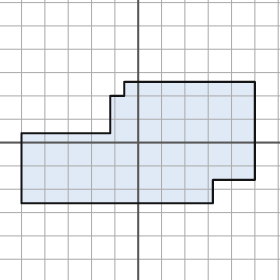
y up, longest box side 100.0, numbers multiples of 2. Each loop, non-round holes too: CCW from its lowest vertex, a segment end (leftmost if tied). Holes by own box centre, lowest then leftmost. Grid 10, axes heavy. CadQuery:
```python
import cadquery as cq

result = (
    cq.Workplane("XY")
    .moveTo(-50.0, -26.0)
    .lineTo(32.0, -26.0)
    .lineTo(32.0, -16.0)
    .lineTo(50.0, -16.0)
    .lineTo(50.0, 26.0)
    .lineTo(-6.0, 26.0)
    .lineTo(-6.0, 20.0)
    .lineTo(-12.0, 20.0)
    .lineTo(-12.0, 4.0)
    .lineTo(-50.0, 4.0)
    .close()
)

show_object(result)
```